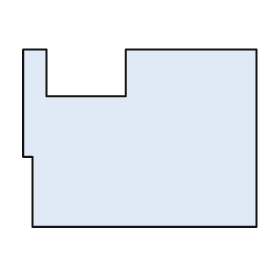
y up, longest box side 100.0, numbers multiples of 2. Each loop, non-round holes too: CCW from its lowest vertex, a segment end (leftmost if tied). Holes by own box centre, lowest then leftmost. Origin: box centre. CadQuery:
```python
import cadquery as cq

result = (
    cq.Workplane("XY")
    .moveTo(-46.0, -38.0)
    .lineTo(50.0, -38.0)
    .lineTo(50.0, 38.0)
    .lineTo(-6.0, 38.0)
    .lineTo(-6.0, 18.0)
    .lineTo(-40.0, 18.0)
    .lineTo(-40.0, 38.0)
    .lineTo(-50.0, 38.0)
    .lineTo(-50.0, -8.0)
    .lineTo(-46.0, -8.0)
    .close()
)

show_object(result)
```